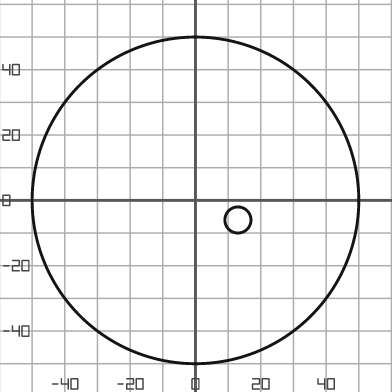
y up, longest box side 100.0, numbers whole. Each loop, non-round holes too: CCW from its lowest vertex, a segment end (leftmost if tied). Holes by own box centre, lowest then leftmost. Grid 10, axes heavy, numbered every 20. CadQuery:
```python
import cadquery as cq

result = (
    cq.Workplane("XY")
    .moveTo(0.0, 0.0)
    .circle(50.0)
    .moveTo(13.0, -6.0)
    .circle(4.0)
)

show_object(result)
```